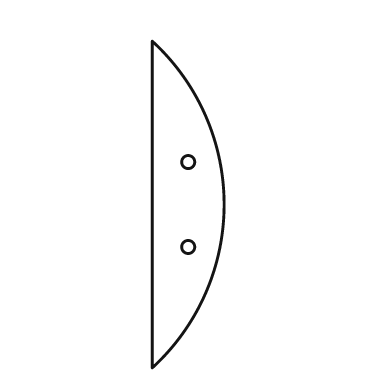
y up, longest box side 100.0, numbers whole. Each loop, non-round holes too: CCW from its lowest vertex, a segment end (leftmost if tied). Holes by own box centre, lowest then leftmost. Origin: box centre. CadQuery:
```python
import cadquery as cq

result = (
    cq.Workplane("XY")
    .moveTo(-11.0, -50.0)
    .threePointArc((11.0, 0.0), (-11.0, 50.0))
    .close()
    .moveTo(0.0, -13.0)
    .circle(2.0)
    .moveTo(0.0, 13.0)
    .circle(2.0)
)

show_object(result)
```